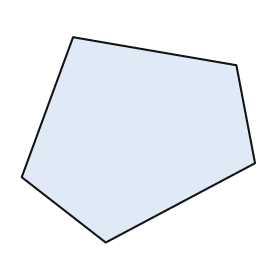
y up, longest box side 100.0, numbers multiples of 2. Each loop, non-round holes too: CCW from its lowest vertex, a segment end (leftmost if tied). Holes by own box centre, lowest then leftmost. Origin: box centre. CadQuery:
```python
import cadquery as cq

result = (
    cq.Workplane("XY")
    .moveTo(-14.0, -44.0)
    .lineTo(50.0, -10.0)
    .lineTo(42.0, 32.0)
    .lineTo(-28.0, 44.0)
    .lineTo(-50.0, -16.0)
    .close()
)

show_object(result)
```